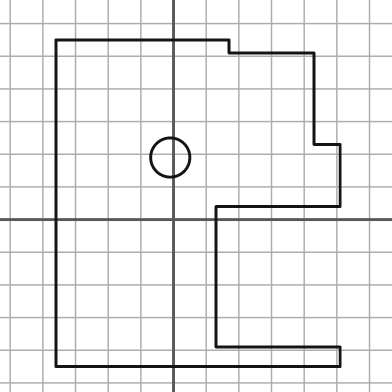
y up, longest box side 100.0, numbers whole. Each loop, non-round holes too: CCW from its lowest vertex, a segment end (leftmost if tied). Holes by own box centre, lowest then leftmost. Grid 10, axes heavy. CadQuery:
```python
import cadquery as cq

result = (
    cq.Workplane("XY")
    .moveTo(-36.0, -45.0)
    .lineTo(51.0, -45.0)
    .lineTo(51.0, -39.0)
    .lineTo(13.0, -39.0)
    .lineTo(13.0, 4.0)
    .lineTo(51.0, 4.0)
    .lineTo(51.0, 23.0)
    .lineTo(43.0, 23.0)
    .lineTo(43.0, 51.0)
    .lineTo(17.0, 51.0)
    .lineTo(17.0, 55.0)
    .lineTo(-36.0, 55.0)
    .close()
    .moveTo(-1.0, 19.0)
    .circle(6.0)
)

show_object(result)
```